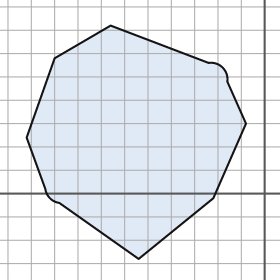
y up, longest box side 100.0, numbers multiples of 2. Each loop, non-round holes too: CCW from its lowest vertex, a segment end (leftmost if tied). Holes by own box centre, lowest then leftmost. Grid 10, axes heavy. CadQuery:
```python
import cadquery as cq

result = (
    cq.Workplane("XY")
    .moveTo(-54.0, -28.0)
    .lineTo(-22.0, -2.0)
    .lineTo(-8.0, 30.0)
    .lineTo(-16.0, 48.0)
    .threePointArc((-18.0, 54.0), (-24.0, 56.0))
    .lineTo(-66.0, 72.0)
    .lineTo(-90.0, 58.0)
    .lineTo(-102.0, 24.0)
    .lineTo(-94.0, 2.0)
    .threePointArc((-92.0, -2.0), (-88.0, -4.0))
    .close()
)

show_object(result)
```